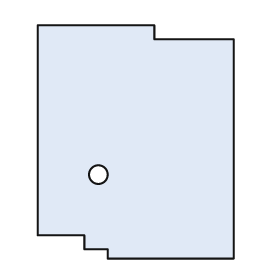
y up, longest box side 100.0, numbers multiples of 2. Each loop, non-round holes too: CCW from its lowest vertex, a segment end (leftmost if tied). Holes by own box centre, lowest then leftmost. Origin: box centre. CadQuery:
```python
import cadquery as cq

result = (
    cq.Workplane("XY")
    .moveTo(-12.0, -50.0)
    .lineTo(42.0, -50.0)
    .lineTo(42.0, 44.0)
    .lineTo(8.0, 44.0)
    .lineTo(8.0, 50.0)
    .lineTo(-42.0, 50.0)
    .lineTo(-42.0, -40.0)
    .lineTo(-22.0, -40.0)
    .lineTo(-22.0, -46.0)
    .lineTo(-12.0, -46.0)
    .close()
    .moveTo(-16.0, -14.0)
    .circle(4.0)
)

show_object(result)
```